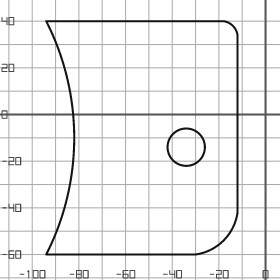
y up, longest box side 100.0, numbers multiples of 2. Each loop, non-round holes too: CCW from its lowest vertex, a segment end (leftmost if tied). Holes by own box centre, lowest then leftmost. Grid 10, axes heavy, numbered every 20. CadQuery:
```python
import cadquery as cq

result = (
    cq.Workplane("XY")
    .moveTo(-94.0, -60.0)
    .lineTo(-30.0, -60.0)
    .threePointArc((-18.0, -54.0), (-12.0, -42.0))
    .lineTo(-12.0, 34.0)
    .threePointArc((-14.0, 38.0), (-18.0, 40.0))
    .lineTo(-94.0, 40.0)
    .threePointArc((-82.0, -10.0), (-94.0, -60.0))
    .close()
    .moveTo(-34.0, -14.0)
    .circle(8.0)
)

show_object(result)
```